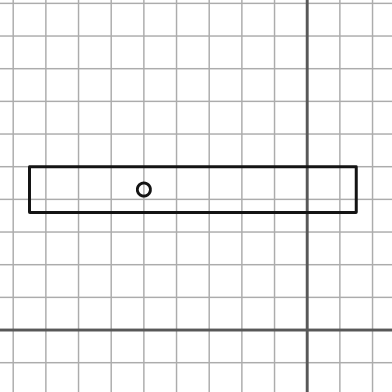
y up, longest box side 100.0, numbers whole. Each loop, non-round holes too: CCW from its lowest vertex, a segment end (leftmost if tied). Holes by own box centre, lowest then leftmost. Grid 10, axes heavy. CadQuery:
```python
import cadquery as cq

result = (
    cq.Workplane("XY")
    .moveTo(-85.0, 36.0)
    .lineTo(15.0, 36.0)
    .lineTo(15.0, 50.0)
    .lineTo(-85.0, 50.0)
    .close()
    .moveTo(-50.0, 43.0)
    .circle(2.0)
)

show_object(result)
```